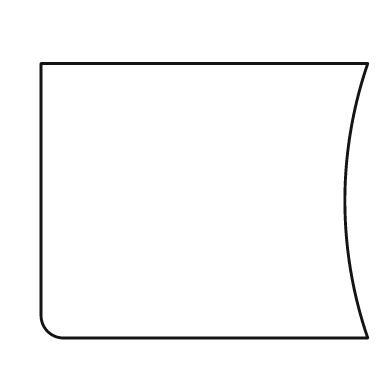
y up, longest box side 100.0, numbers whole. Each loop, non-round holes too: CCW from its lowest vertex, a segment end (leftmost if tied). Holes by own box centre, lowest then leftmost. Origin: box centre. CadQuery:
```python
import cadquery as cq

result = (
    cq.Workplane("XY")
    .moveTo(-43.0, -42.0)
    .lineTo(50.0, -42.0)
    .threePointArc((43.0, 0.0), (50.0, 42.0))
    .lineTo(-50.0, 42.0)
    .lineTo(-50.0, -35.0)
    .threePointArc((-48.0, -40.0), (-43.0, -42.0))
    .close()
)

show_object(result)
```